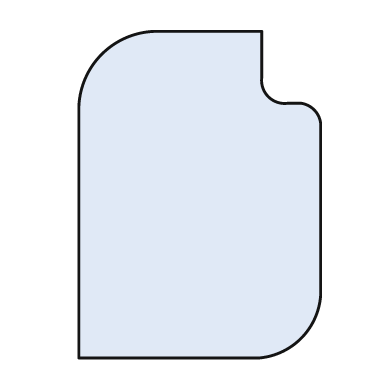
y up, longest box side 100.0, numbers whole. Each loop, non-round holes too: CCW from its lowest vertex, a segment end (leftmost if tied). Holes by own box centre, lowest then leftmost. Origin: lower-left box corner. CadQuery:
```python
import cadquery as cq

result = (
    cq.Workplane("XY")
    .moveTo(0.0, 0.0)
    .lineTo(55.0, 0.0)
    .threePointArc((68.0, 6.0), (74.0, 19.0))
    .lineTo(74.0, 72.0)
    .threePointArc((72.0, 76.0), (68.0, 78.0))
    .lineTo(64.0, 78.0)
    .threePointArc((58.0, 80.0), (56.0, 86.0))
    .lineTo(56.0, 100.0)
    .lineTo(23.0, 100.0)
    .threePointArc((7.0, 93.0), (0.0, 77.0))
    .close()
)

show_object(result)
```